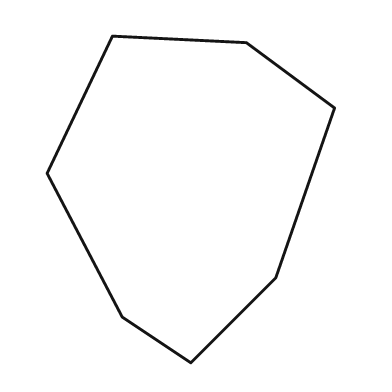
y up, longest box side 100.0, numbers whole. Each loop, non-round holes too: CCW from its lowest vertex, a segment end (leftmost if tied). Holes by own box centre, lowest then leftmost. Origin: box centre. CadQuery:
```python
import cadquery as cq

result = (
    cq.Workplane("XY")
    .moveTo(0.0, -50.0)
    .lineTo(26.0, -24.0)
    .lineTo(44.0, 28.0)
    .lineTo(17.0, 48.0)
    .lineTo(-24.0, 50.0)
    .lineTo(-44.0, 8.0)
    .lineTo(-21.0, -36.0)
    .close()
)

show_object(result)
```